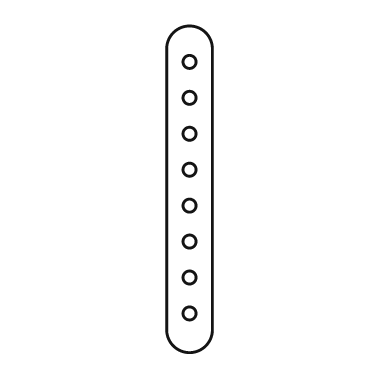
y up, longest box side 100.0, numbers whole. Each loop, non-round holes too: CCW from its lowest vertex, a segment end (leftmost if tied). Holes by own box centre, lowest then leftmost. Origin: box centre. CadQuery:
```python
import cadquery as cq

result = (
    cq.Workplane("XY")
    .moveTo(-7.0, -43.0)
    .threePointArc((0.0, -50.0), (7.0, -43.0))
    .lineTo(7.0, 43.0)
    .threePointArc((0.0, 50.0), (-7.0, 43.0))
    .close()
    .moveTo(0.0, -38.0)
    .circle(2.0)
    .moveTo(0.0, -27.0)
    .circle(2.0)
    .moveTo(0.0, -16.0)
    .circle(2.0)
    .moveTo(0.0, -5.0)
    .circle(2.0)
    .moveTo(0.0, 6.0)
    .circle(2.0)
    .moveTo(0.0, 17.0)
    .circle(2.0)
    .moveTo(0.0, 28.0)
    .circle(2.0)
    .moveTo(0.0, 39.0)
    .circle(2.0)
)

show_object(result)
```